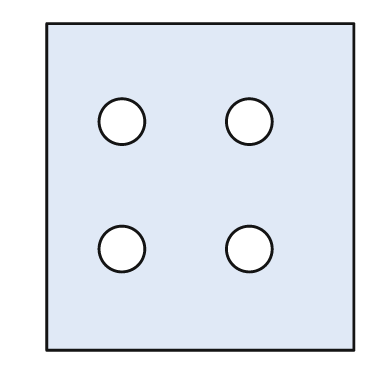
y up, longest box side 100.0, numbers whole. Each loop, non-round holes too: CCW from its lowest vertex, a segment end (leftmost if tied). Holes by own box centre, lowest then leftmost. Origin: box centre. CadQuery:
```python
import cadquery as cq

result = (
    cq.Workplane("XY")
    .moveTo(-47.0, -50.0)
    .lineTo(47.0, -50.0)
    .lineTo(47.0, 50.0)
    .lineTo(-47.0, 50.0)
    .close()
    .moveTo(-24.0, -19.0)
    .circle(7.0)
    .moveTo(15.0, -19.0)
    .circle(7.0)
    .moveTo(-24.0, 20.0)
    .circle(7.0)
    .moveTo(15.0, 20.0)
    .circle(7.0)
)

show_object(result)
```